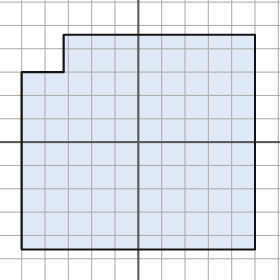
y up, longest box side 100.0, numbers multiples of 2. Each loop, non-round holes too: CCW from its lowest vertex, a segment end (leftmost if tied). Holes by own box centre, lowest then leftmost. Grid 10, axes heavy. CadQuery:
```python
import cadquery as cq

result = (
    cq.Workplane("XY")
    .moveTo(-50.0, -46.0)
    .lineTo(50.0, -46.0)
    .lineTo(50.0, 46.0)
    .lineTo(-32.0, 46.0)
    .lineTo(-32.0, 30.0)
    .lineTo(-50.0, 30.0)
    .close()
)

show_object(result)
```